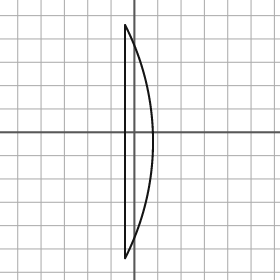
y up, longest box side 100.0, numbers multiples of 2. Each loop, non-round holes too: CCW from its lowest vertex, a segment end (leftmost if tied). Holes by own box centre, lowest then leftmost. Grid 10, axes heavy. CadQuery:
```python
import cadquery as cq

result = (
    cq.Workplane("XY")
    .moveTo(-4.0, -54.0)
    .threePointArc((8.0, -4.0), (-4.0, 46.0))
    .close()
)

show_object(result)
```